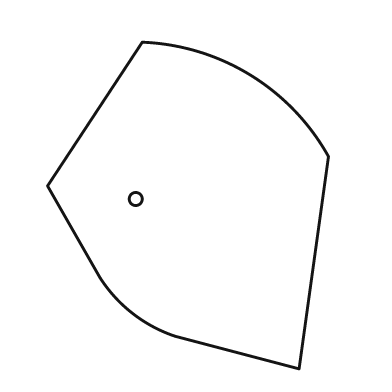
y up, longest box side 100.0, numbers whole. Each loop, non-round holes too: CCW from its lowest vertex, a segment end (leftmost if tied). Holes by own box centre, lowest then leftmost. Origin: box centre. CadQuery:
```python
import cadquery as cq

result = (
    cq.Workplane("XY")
    .moveTo(34.0, -50.0)
    .lineTo(43.0, 15.0)
    .threePointArc((19.0, 40.0), (-14.0, 50.0))
    .lineTo(-43.0, 6.0)
    .lineTo(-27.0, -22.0)
    .threePointArc((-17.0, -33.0), (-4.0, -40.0))
    .close()
    .moveTo(-16.0, 2.0)
    .circle(2.0)
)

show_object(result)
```